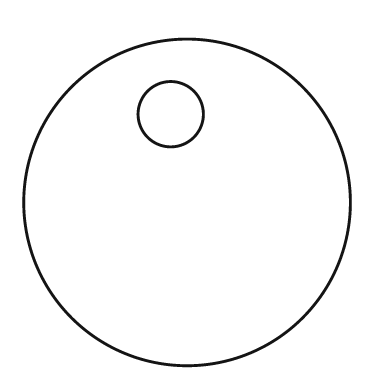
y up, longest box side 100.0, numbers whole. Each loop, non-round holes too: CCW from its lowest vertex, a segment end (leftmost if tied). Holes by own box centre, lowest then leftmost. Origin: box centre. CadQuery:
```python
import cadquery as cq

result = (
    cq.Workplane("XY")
    .moveTo(0.0, 0.0)
    .circle(50.0)
    .moveTo(-5.0, 27.0)
    .circle(10.0)
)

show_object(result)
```